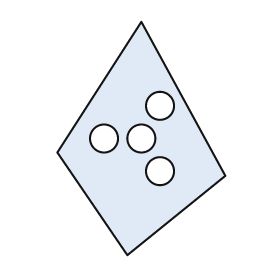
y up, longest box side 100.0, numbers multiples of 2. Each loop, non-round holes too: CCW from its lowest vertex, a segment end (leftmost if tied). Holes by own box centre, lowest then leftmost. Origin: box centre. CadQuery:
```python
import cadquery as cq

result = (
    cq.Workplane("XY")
    .moveTo(-6.0, -50.0)
    .lineTo(36.0, -16.0)
    .lineTo(0.0, 50.0)
    .lineTo(-36.0, -6.0)
    .close()
    .moveTo(8.0, -14.0)
    .circle(6.0)
    .moveTo(-16.0, 0.0)
    .circle(6.0)
    .moveTo(0.0, 0.0)
    .circle(6.0)
    .moveTo(8.0, 14.0)
    .circle(6.0)
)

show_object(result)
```